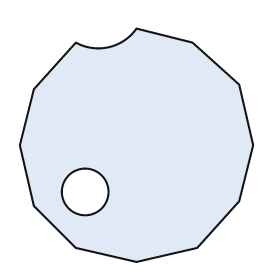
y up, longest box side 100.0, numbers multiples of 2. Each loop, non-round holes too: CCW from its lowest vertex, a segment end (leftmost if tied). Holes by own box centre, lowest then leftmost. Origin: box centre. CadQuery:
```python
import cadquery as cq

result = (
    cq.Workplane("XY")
    .moveTo(0.0, -50.0)
    .lineTo(26.0, -44.0)
    .lineTo(44.0, -24.0)
    .lineTo(50.0, 0.0)
    .lineTo(44.0, 26.0)
    .lineTo(24.0, 44.0)
    .lineTo(0.0, 50.0)
    .threePointArc((-12.0, 42.0), (-26.0, 44.0))
    .lineTo(-44.0, 24.0)
    .lineTo(-50.0, 0.0)
    .lineTo(-44.0, -26.0)
    .lineTo(-26.0, -44.0)
    .close()
    .moveTo(-22.0, -20.0)
    .circle(10.0)
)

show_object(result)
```